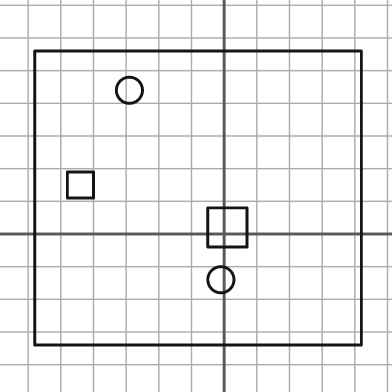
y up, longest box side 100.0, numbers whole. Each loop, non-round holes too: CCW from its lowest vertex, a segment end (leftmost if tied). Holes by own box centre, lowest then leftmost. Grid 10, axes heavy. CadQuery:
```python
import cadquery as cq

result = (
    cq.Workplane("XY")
    .moveTo(-58.0, -34.0)
    .lineTo(42.0, -34.0)
    .lineTo(42.0, 56.0)
    .lineTo(-58.0, 56.0)
    .close()
    .moveTo(-1.0, -14.0)
    .circle(4.0)
    .moveTo(-5.0, -4.0)
    .lineTo(7.0, -4.0)
    .lineTo(7.0, 8.0)
    .lineTo(-5.0, 8.0)
    .close()
    .moveTo(-48.0, 11.0)
    .lineTo(-40.0, 11.0)
    .lineTo(-40.0, 19.0)
    .lineTo(-48.0, 19.0)
    .close()
    .moveTo(-29.0, 44.0)
    .circle(4.0)
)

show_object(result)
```